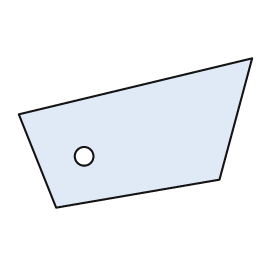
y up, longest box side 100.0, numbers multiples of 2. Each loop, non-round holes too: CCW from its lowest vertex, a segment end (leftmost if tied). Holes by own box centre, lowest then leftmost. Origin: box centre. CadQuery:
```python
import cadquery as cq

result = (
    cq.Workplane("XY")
    .moveTo(-34.0, -32.0)
    .lineTo(36.0, -20.0)
    .lineTo(50.0, 32.0)
    .lineTo(-50.0, 8.0)
    .close()
    .moveTo(-22.0, -10.0)
    .circle(4.0)
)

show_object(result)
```